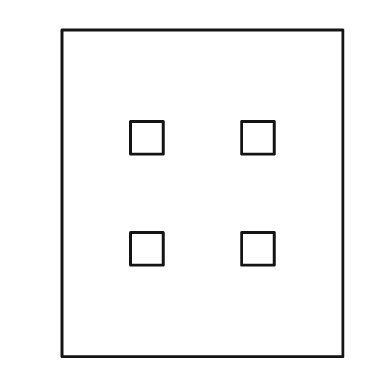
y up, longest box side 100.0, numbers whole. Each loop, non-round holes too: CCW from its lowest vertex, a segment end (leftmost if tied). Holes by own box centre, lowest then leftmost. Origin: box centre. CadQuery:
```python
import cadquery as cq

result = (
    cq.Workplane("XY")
    .moveTo(-43.0, -50.0)
    .lineTo(43.0, -50.0)
    .lineTo(43.0, 50.0)
    .lineTo(-43.0, 50.0)
    .close()
    .moveTo(-22.0, -22.0)
    .lineTo(-12.0, -22.0)
    .lineTo(-12.0, -12.0)
    .lineTo(-22.0, -12.0)
    .close()
    .moveTo(12.0, -22.0)
    .lineTo(22.0, -22.0)
    .lineTo(22.0, -12.0)
    .lineTo(12.0, -12.0)
    .close()
    .moveTo(-22.0, 12.0)
    .lineTo(-12.0, 12.0)
    .lineTo(-12.0, 22.0)
    .lineTo(-22.0, 22.0)
    .close()
    .moveTo(12.0, 12.0)
    .lineTo(22.0, 12.0)
    .lineTo(22.0, 22.0)
    .lineTo(12.0, 22.0)
    .close()
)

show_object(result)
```